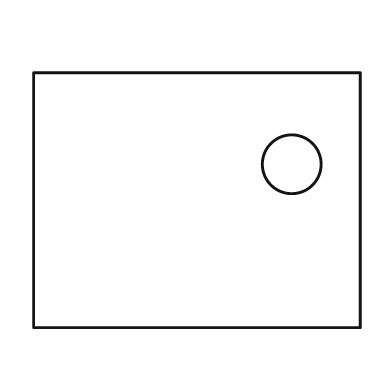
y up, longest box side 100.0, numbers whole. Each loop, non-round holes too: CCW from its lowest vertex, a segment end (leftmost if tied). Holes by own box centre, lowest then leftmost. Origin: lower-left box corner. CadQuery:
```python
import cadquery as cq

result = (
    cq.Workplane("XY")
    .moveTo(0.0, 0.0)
    .lineTo(100.0, 0.0)
    .lineTo(100.0, 78.0)
    .lineTo(0.0, 78.0)
    .close()
    .moveTo(79.0, 50.0)
    .circle(9.0)
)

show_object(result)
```